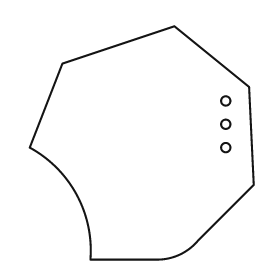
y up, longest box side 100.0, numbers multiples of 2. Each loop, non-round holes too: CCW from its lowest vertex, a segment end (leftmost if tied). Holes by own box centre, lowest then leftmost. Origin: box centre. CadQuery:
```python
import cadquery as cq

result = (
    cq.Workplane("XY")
    .moveTo(-22.0, -50.0)
    .lineTo(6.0, -50.0)
    .threePointArc((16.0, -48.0), (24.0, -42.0))
    .lineTo(48.0, -18.0)
    .lineTo(46.0, 24.0)
    .lineTo(14.0, 50.0)
    .lineTo(-34.0, 34.0)
    .lineTo(-48.0, -2.0)
    .threePointArc((-28.0, -22.0), (-22.0, -50.0))
    .close()
    .moveTo(36.0, -2.0)
    .circle(2.0)
    .moveTo(36.0, 8.0)
    .circle(2.0)
    .moveTo(36.0, 18.0)
    .circle(2.0)
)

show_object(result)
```